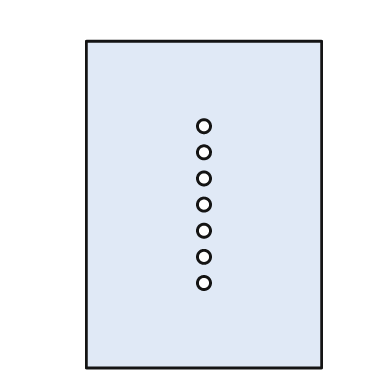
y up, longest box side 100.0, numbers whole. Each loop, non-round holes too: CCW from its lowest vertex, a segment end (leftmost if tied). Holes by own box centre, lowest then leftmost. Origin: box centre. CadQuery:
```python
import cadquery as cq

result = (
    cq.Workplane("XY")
    .moveTo(-36.0, -50.0)
    .lineTo(36.0, -50.0)
    .lineTo(36.0, 50.0)
    .lineTo(-36.0, 50.0)
    .close()
    .moveTo(0.0, -24.0)
    .circle(2.0)
    .moveTo(0.0, -16.0)
    .circle(2.0)
    .moveTo(0.0, -8.0)
    .circle(2.0)
    .moveTo(0.0, 0.0)
    .circle(2.0)
    .moveTo(0.0, 8.0)
    .circle(2.0)
    .moveTo(0.0, 16.0)
    .circle(2.0)
    .moveTo(0.0, 24.0)
    .circle(2.0)
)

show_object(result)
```